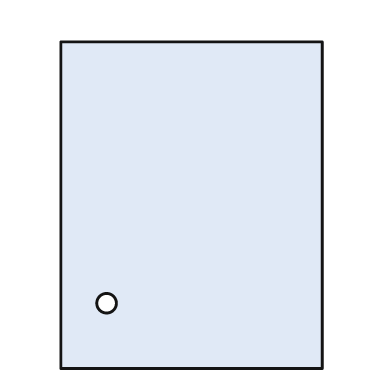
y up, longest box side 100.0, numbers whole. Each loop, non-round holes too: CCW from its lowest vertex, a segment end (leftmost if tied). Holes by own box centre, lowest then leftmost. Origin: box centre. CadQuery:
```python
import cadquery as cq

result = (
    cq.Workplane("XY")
    .moveTo(-40.0, -50.0)
    .lineTo(40.0, -50.0)
    .lineTo(40.0, 50.0)
    .lineTo(-40.0, 50.0)
    .close()
    .moveTo(-26.0, -30.0)
    .circle(3.0)
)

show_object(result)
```